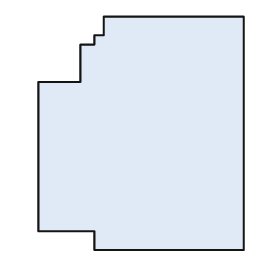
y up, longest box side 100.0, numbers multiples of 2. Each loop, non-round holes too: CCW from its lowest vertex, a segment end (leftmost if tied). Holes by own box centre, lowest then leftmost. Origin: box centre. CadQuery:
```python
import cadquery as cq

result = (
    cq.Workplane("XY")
    .moveTo(-20.0, -50.0)
    .lineTo(44.0, -50.0)
    .lineTo(44.0, 50.0)
    .lineTo(-16.0, 50.0)
    .lineTo(-16.0, 42.0)
    .lineTo(-20.0, 42.0)
    .lineTo(-20.0, 38.0)
    .lineTo(-26.0, 38.0)
    .lineTo(-26.0, 22.0)
    .lineTo(-44.0, 22.0)
    .lineTo(-44.0, -42.0)
    .lineTo(-20.0, -42.0)
    .close()
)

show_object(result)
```